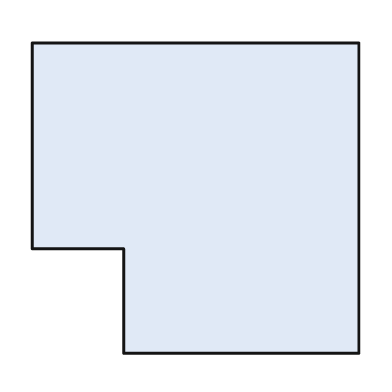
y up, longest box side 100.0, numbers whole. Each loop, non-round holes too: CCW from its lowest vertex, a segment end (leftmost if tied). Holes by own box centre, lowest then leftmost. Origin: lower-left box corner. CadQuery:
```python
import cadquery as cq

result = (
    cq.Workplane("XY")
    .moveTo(28.0, 0.0)
    .lineTo(100.0, 0.0)
    .lineTo(100.0, 95.0)
    .lineTo(0.0, 95.0)
    .lineTo(0.0, 32.0)
    .lineTo(28.0, 32.0)
    .close()
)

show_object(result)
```